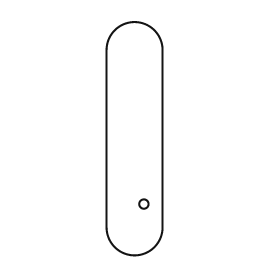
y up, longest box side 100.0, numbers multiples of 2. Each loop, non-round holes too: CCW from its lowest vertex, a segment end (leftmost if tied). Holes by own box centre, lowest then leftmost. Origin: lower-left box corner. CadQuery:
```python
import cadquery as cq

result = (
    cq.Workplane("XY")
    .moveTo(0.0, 12.0)
    .threePointArc((12.0, 0.0), (24.0, 12.0))
    .lineTo(24.0, 88.0)
    .threePointArc((12.0, 100.0), (0.0, 88.0))
    .close()
    .moveTo(16.0, 22.0)
    .circle(2.0)
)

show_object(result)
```